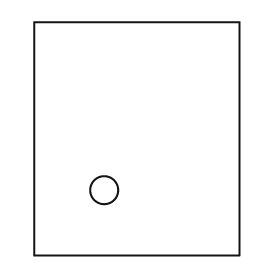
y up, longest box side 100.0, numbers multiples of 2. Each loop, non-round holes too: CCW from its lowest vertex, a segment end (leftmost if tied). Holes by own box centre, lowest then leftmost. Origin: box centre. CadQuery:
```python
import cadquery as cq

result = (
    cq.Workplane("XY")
    .moveTo(-44.0, -50.0)
    .lineTo(44.0, -50.0)
    .lineTo(44.0, 50.0)
    .lineTo(-44.0, 50.0)
    .close()
    .moveTo(-14.0, -22.0)
    .circle(6.0)
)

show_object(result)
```